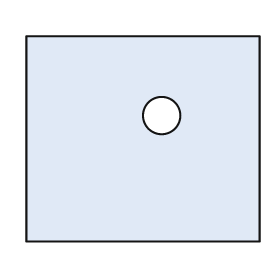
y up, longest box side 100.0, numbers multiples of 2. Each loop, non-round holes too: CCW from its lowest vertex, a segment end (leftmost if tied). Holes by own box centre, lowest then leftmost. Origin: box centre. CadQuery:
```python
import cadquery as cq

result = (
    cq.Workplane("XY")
    .moveTo(-50.0, -44.0)
    .lineTo(50.0, -44.0)
    .lineTo(50.0, 44.0)
    .lineTo(-50.0, 44.0)
    .close()
    .moveTo(8.0, 10.0)
    .circle(8.0)
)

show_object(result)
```